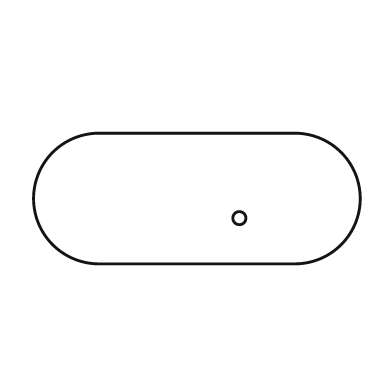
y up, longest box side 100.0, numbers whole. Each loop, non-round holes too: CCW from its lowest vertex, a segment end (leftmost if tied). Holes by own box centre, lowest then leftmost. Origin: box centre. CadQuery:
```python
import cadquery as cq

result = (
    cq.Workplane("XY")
    .moveTo(-30.0, -20.0)
    .lineTo(30.0, -20.0)
    .threePointArc((50.0, 0.0), (30.0, 20.0))
    .lineTo(-30.0, 20.0)
    .threePointArc((-50.0, 0.0), (-30.0, -20.0))
    .close()
    .moveTo(13.0, -6.0)
    .circle(2.0)
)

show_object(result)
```